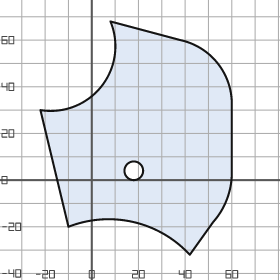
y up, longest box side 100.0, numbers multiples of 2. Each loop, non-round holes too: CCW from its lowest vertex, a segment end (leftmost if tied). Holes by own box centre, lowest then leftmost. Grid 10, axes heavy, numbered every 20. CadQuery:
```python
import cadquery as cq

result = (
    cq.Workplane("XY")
    .moveTo(42.0, -32.0)
    .lineTo(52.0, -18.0)
    .threePointArc((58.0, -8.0), (60.0, 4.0))
    .lineTo(60.0, 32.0)
    .threePointArc((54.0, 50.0), (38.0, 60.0))
    .lineTo(8.0, 68.0)
    .threePointArc((4.0, 40.0), (-22.0, 30.0))
    .lineTo(-10.0, -20.0)
    .threePointArc((18.0, -18.0), (42.0, -32.0))
    .close()
    .moveTo(18.0, 4.0)
    .circle(4.0)
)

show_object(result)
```